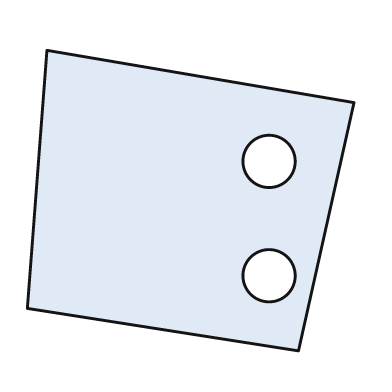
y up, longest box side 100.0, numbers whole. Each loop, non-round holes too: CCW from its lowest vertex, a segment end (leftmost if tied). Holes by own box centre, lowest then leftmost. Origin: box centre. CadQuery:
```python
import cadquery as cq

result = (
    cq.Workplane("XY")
    .moveTo(33.0, -46.0)
    .lineTo(50.0, 30.0)
    .lineTo(-44.0, 46.0)
    .lineTo(-50.0, -33.0)
    .close()
    .moveTo(24.0, -23.0)
    .circle(8.0)
    .moveTo(24.0, 12.0)
    .circle(8.0)
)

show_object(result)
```